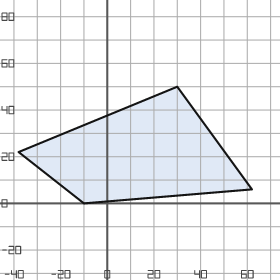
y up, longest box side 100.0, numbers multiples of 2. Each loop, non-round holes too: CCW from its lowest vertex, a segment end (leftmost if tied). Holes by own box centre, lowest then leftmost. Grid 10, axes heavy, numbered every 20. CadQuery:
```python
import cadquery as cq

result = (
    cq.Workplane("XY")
    .moveTo(-10.0, 0.0)
    .lineTo(62.0, 6.0)
    .lineTo(30.0, 50.0)
    .lineTo(-38.0, 22.0)
    .close()
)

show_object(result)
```